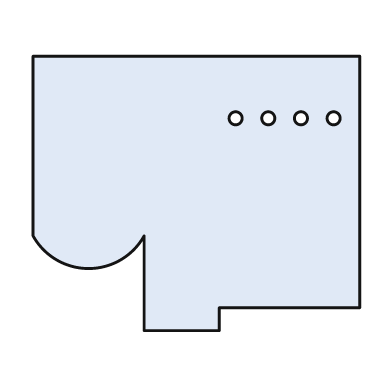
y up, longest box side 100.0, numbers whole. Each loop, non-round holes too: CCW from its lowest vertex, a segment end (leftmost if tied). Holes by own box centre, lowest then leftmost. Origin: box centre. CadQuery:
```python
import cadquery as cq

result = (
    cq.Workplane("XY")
    .moveTo(-16.0, -42.0)
    .lineTo(7.0, -42.0)
    .lineTo(7.0, -35.0)
    .lineTo(50.0, -35.0)
    .lineTo(50.0, 42.0)
    .lineTo(-50.0, 42.0)
    .lineTo(-50.0, -13.0)
    .threePointArc((-33.0, -23.0), (-16.0, -13.0))
    .close()
    .moveTo(12.0, 23.0)
    .circle(2.0)
    .moveTo(22.0, 23.0)
    .circle(2.0)
    .moveTo(32.0, 23.0)
    .circle(2.0)
    .moveTo(42.0, 23.0)
    .circle(2.0)
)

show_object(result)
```